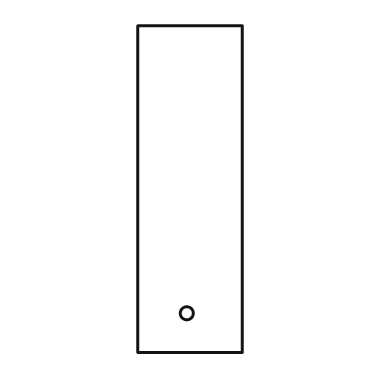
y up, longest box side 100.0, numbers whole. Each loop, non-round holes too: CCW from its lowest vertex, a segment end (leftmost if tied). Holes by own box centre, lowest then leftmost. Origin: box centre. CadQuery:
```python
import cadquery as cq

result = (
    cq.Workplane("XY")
    .moveTo(-16.0, -50.0)
    .lineTo(16.0, -50.0)
    .lineTo(16.0, 50.0)
    .lineTo(-16.0, 50.0)
    .close()
    .moveTo(-1.0, -38.0)
    .circle(2.0)
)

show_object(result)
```